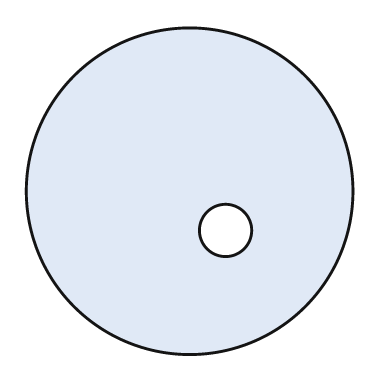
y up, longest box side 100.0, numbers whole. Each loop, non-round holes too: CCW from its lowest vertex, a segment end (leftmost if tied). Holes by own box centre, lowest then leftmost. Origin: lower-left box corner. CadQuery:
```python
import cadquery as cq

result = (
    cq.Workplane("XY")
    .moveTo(50.0, 50.0)
    .circle(50.0)
    .moveTo(61.0, 38.0)
    .circle(8.0)
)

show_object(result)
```